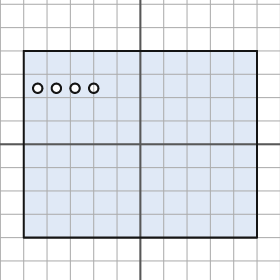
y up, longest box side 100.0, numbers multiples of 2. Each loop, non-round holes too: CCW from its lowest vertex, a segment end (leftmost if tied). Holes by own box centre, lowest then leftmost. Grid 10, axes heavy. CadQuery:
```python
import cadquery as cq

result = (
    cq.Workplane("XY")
    .moveTo(-50.0, -40.0)
    .lineTo(50.0, -40.0)
    .lineTo(50.0, 40.0)
    .lineTo(-50.0, 40.0)
    .close()
    .moveTo(-44.0, 24.0)
    .circle(2.0)
    .moveTo(-36.0, 24.0)
    .circle(2.0)
    .moveTo(-28.0, 24.0)
    .circle(2.0)
    .moveTo(-20.0, 24.0)
    .circle(2.0)
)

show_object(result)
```